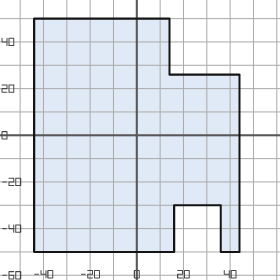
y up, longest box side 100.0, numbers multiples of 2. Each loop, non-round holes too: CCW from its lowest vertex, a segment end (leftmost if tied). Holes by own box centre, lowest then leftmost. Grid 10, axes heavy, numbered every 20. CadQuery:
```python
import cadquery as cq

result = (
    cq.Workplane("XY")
    .moveTo(-44.0, -50.0)
    .lineTo(16.0, -50.0)
    .lineTo(16.0, -30.0)
    .lineTo(36.0, -30.0)
    .lineTo(36.0, -50.0)
    .lineTo(44.0, -50.0)
    .lineTo(44.0, 26.0)
    .lineTo(14.0, 26.0)
    .lineTo(14.0, 50.0)
    .lineTo(-44.0, 50.0)
    .close()
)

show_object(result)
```